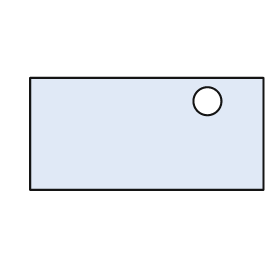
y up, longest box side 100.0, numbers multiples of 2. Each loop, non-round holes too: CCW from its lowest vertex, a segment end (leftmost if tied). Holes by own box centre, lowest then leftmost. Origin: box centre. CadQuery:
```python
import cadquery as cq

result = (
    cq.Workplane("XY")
    .moveTo(-50.0, -24.0)
    .lineTo(50.0, -24.0)
    .lineTo(50.0, 24.0)
    .lineTo(-50.0, 24.0)
    .close()
    .moveTo(26.0, 14.0)
    .circle(6.0)
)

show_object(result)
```